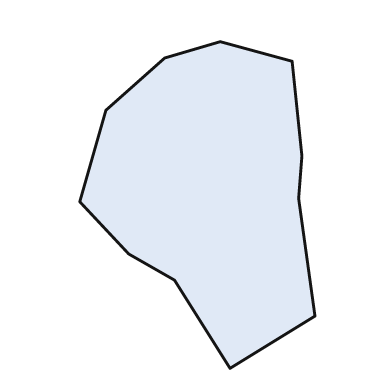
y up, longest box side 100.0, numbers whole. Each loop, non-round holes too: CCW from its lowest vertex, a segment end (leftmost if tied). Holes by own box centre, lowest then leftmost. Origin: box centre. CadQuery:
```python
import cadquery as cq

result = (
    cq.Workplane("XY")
    .moveTo(10.0, -50.0)
    .lineTo(36.0, -34.0)
    .lineTo(31.0, 2.0)
    .lineTo(32.0, 15.0)
    .lineTo(29.0, 44.0)
    .lineTo(7.0, 50.0)
    .lineTo(-10.0, 45.0)
    .lineTo(-28.0, 29.0)
    .lineTo(-36.0, 1.0)
    .lineTo(-21.0, -15.0)
    .lineTo(-7.0, -23.0)
    .close()
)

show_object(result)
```